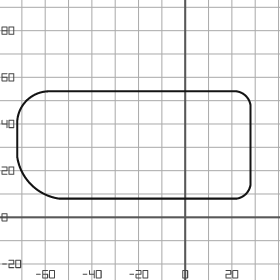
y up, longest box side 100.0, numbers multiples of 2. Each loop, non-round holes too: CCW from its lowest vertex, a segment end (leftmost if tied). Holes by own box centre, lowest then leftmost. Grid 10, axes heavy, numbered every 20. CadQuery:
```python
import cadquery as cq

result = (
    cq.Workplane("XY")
    .moveTo(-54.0, 8.0)
    .lineTo(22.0, 8.0)
    .threePointArc((26.0, 10.0), (28.0, 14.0))
    .lineTo(28.0, 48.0)
    .threePointArc((26.0, 52.0), (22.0, 54.0))
    .lineTo(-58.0, 54.0)
    .threePointArc((-68.0, 50.0), (-72.0, 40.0))
    .lineTo(-72.0, 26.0)
    .threePointArc((-66.0, 14.0), (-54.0, 8.0))
    .close()
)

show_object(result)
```